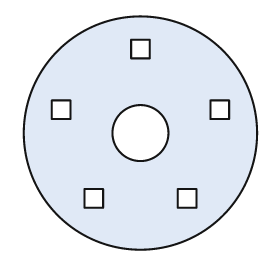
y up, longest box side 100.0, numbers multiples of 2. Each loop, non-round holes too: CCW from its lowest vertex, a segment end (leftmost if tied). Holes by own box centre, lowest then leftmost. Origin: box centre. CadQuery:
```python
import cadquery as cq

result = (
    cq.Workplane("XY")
    .moveTo(0.0, 0.0)
    .circle(50.0)
    .moveTo(-24.0, -32.0)
    .lineTo(-16.0, -32.0)
    .lineTo(-16.0, -24.0)
    .lineTo(-24.0, -24.0)
    .close()
    .moveTo(16.0, -32.0)
    .lineTo(24.0, -32.0)
    .lineTo(24.0, -24.0)
    .lineTo(16.0, -24.0)
    .close()
    .moveTo(0.0, 0.0)
    .circle(12.0)
    .moveTo(-38.0, 6.0)
    .lineTo(-30.0, 6.0)
    .lineTo(-30.0, 14.0)
    .lineTo(-38.0, 14.0)
    .close()
    .moveTo(30.0, 6.0)
    .lineTo(38.0, 6.0)
    .lineTo(38.0, 14.0)
    .lineTo(30.0, 14.0)
    .close()
    .moveTo(-4.0, 32.0)
    .lineTo(4.0, 32.0)
    .lineTo(4.0, 40.0)
    .lineTo(-4.0, 40.0)
    .close()
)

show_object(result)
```